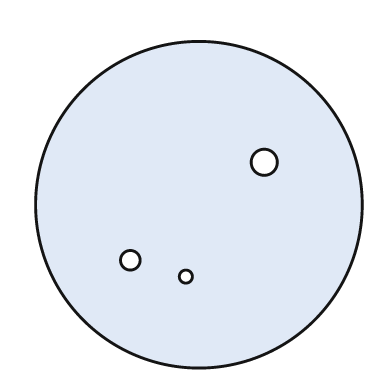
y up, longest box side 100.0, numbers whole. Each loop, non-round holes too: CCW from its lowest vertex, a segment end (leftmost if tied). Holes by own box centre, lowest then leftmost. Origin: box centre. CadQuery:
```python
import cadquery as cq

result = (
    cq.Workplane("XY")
    .moveTo(0.0, 0.0)
    .circle(50.0)
    .moveTo(-4.0, -22.0)
    .circle(2.0)
    .moveTo(-21.0, -17.0)
    .circle(3.0)
    .moveTo(20.0, 13.0)
    .circle(4.0)
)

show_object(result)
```